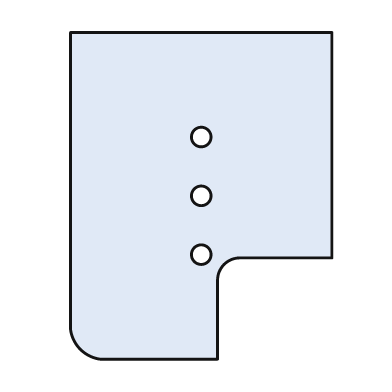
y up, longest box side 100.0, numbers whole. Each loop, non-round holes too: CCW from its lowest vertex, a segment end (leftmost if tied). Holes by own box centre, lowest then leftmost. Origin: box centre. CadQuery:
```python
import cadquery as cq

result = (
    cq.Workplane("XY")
    .moveTo(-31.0, -50.0)
    .lineTo(5.0, -50.0)
    .lineTo(5.0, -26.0)
    .threePointArc((7.0, -21.0), (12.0, -19.0))
    .lineTo(40.0, -19.0)
    .lineTo(40.0, 50.0)
    .lineTo(-40.0, 50.0)
    .lineTo(-40.0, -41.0)
    .threePointArc((-37.0, -47.0), (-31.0, -50.0))
    .close()
    .moveTo(0.0, -18.0)
    .circle(3.0)
    .moveTo(0.0, 0.0)
    .circle(3.0)
    .moveTo(0.0, 18.0)
    .circle(3.0)
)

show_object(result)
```